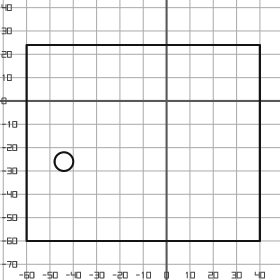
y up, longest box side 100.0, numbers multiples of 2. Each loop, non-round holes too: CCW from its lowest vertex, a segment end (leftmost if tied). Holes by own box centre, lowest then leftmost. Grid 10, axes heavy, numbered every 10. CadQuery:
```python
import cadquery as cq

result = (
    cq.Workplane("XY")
    .moveTo(-60.0, -60.0)
    .lineTo(40.0, -60.0)
    .lineTo(40.0, 24.0)
    .lineTo(-60.0, 24.0)
    .close()
    .moveTo(-44.0, -26.0)
    .circle(4.0)
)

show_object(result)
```